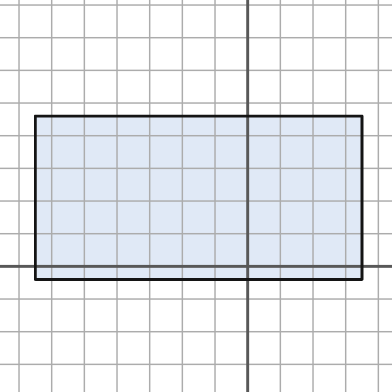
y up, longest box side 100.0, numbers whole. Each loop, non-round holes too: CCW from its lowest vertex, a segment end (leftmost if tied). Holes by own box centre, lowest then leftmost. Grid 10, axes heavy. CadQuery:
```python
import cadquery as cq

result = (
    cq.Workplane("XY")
    .moveTo(-65.0, -4.0)
    .lineTo(35.0, -4.0)
    .lineTo(35.0, 46.0)
    .lineTo(-65.0, 46.0)
    .close()
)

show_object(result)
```